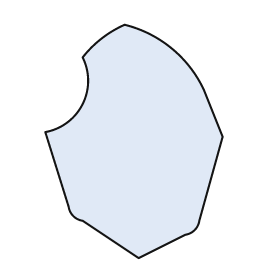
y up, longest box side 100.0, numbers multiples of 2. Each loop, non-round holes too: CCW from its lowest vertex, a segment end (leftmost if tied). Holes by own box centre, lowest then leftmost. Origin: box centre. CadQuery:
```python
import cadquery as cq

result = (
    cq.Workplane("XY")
    .moveTo(2.0, -50.0)
    .lineTo(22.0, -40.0)
    .threePointArc((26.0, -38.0), (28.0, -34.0))
    .lineTo(38.0, 2.0)
    .lineTo(30.0, 22.0)
    .threePointArc((16.0, 40.0), (-4.0, 50.0))
    .threePointArc((-14.0, 44.0), (-22.0, 36.0))
    .threePointArc((-22.0, 16.0), (-38.0, 4.0))
    .lineTo(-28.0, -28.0)
    .threePointArc((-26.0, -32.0), (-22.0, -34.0))
    .close()
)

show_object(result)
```